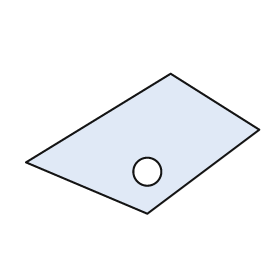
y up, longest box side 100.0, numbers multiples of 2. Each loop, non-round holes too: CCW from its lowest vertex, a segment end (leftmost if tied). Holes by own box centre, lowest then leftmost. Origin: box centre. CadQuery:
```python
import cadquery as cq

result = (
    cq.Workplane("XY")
    .moveTo(2.0, -30.0)
    .lineTo(50.0, 6.0)
    .lineTo(12.0, 30.0)
    .lineTo(-50.0, -8.0)
    .close()
    .moveTo(2.0, -12.0)
    .circle(6.0)
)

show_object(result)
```